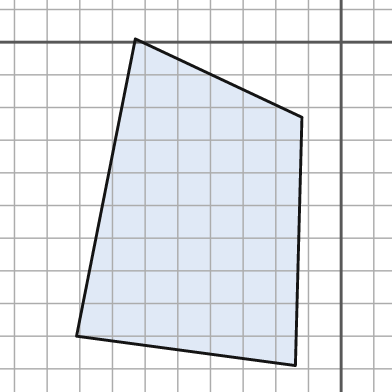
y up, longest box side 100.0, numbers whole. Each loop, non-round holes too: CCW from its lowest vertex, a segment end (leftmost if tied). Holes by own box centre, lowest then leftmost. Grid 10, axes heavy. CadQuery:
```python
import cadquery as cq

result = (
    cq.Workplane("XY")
    .moveTo(-14.0, -99.0)
    .lineTo(-12.0, -23.0)
    .lineTo(-63.0, 1.0)
    .lineTo(-81.0, -90.0)
    .close()
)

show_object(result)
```